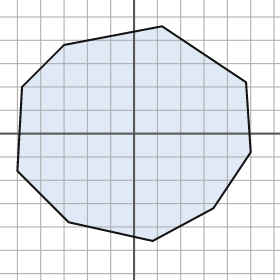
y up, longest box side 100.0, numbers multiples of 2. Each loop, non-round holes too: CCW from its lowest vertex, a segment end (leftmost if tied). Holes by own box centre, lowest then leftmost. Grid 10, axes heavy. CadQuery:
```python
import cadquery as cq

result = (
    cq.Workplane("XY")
    .moveTo(8.0, -46.0)
    .lineTo(34.0, -32.0)
    .lineTo(50.0, -8.0)
    .lineTo(48.0, 22.0)
    .lineTo(12.0, 46.0)
    .lineTo(-30.0, 38.0)
    .lineTo(-48.0, 20.0)
    .lineTo(-50.0, -16.0)
    .lineTo(-28.0, -38.0)
    .close()
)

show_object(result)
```